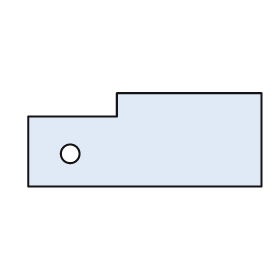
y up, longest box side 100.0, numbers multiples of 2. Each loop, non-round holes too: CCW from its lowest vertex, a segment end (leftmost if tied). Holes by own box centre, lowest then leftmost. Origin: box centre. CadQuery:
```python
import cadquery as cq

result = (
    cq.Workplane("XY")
    .moveTo(-50.0, -20.0)
    .lineTo(50.0, -20.0)
    .lineTo(50.0, 20.0)
    .lineTo(-12.0, 20.0)
    .lineTo(-12.0, 10.0)
    .lineTo(-50.0, 10.0)
    .close()
    .moveTo(-32.0, -6.0)
    .circle(4.0)
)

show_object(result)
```